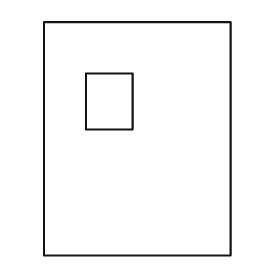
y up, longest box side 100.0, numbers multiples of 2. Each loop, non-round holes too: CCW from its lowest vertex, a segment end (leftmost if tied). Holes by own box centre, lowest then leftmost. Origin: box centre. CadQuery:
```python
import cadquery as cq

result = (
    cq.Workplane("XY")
    .moveTo(-40.0, -50.0)
    .lineTo(40.0, -50.0)
    .lineTo(40.0, 50.0)
    .lineTo(-40.0, 50.0)
    .close()
    .moveTo(-22.0, 4.0)
    .lineTo(-2.0, 4.0)
    .lineTo(-2.0, 28.0)
    .lineTo(-22.0, 28.0)
    .close()
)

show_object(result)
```